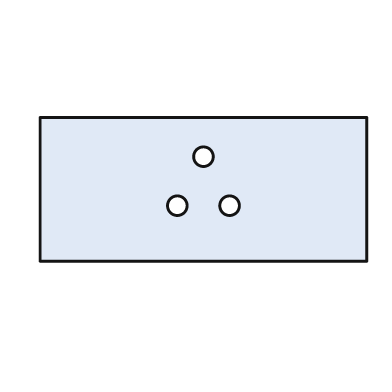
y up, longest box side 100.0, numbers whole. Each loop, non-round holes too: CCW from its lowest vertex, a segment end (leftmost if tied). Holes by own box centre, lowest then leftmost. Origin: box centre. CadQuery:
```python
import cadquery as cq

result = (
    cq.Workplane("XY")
    .moveTo(-50.0, -22.0)
    .lineTo(50.0, -22.0)
    .lineTo(50.0, 22.0)
    .lineTo(-50.0, 22.0)
    .close()
    .moveTo(-8.0, -5.0)
    .circle(3.0)
    .moveTo(8.0, -5.0)
    .circle(3.0)
    .moveTo(0.0, 10.0)
    .circle(3.0)
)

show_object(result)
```